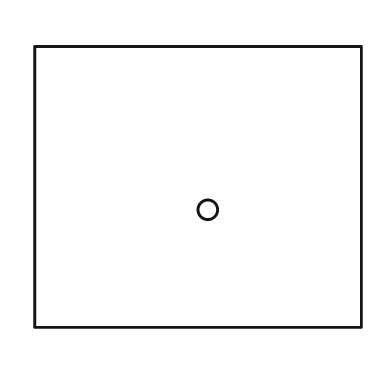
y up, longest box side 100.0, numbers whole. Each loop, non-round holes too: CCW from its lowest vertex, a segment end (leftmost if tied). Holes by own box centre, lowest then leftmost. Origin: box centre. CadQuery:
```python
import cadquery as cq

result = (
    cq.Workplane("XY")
    .moveTo(-50.0, -43.0)
    .lineTo(50.0, -43.0)
    .lineTo(50.0, 43.0)
    .lineTo(-50.0, 43.0)
    .close()
    .moveTo(3.0, -7.0)
    .circle(3.0)
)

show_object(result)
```